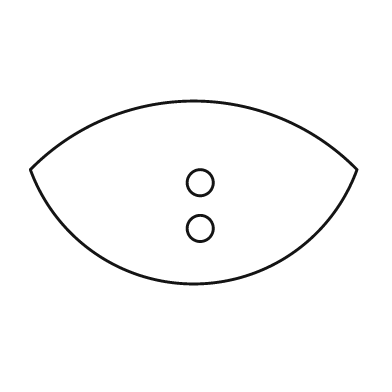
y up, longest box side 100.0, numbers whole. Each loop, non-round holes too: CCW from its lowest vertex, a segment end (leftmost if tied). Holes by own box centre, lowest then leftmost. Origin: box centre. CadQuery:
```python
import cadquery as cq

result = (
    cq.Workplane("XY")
    .moveTo(-50.0, 7.0)
    .threePointArc((0.0, -28.0), (50.0, 7.0))
    .threePointArc((0.0, 28.0), (-50.0, 7.0))
    .close()
    .moveTo(2.0, -11.0)
    .circle(4.0)
    .moveTo(2.0, 3.0)
    .circle(4.0)
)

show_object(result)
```